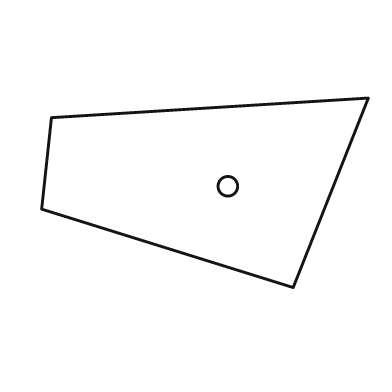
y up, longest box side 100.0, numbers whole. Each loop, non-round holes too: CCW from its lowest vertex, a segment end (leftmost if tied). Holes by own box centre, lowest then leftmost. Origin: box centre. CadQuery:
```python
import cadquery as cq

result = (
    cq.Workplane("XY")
    .moveTo(27.0, -29.0)
    .lineTo(50.0, 29.0)
    .lineTo(-47.0, 23.0)
    .lineTo(-50.0, -5.0)
    .close()
    .moveTo(7.0, 2.0)
    .circle(3.0)
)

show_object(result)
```